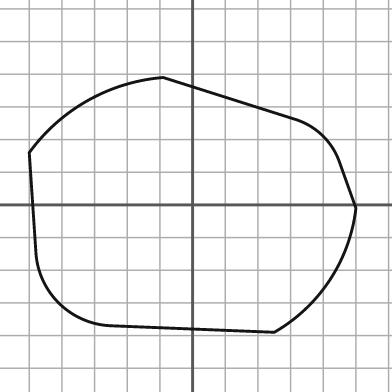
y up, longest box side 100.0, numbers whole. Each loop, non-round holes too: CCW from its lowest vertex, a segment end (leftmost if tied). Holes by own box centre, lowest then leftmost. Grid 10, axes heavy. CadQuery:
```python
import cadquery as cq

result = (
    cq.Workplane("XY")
    .moveTo(25.0, -39.0)
    .threePointArc((42.0, -23.0), (50.0, -1.0))
    .lineTo(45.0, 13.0)
    .threePointArc((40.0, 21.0), (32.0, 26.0))
    .lineTo(-9.0, 39.0)
    .threePointArc((-32.0, 32.0), (-50.0, 16.0))
    .lineTo(-48.0, -14.0)
    .threePointArc((-41.0, -30.0), (-25.0, -37.0))
    .close()
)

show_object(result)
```